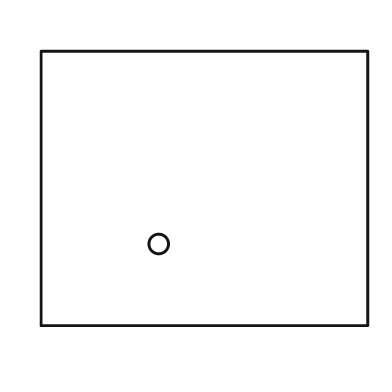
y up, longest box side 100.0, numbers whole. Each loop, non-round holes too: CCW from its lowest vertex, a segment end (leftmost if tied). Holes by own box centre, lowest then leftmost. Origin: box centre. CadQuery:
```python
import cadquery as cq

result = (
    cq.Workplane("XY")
    .moveTo(-50.0, -42.0)
    .lineTo(50.0, -42.0)
    .lineTo(50.0, 42.0)
    .lineTo(-50.0, 42.0)
    .close()
    .moveTo(-14.0, -17.0)
    .circle(3.0)
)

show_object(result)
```